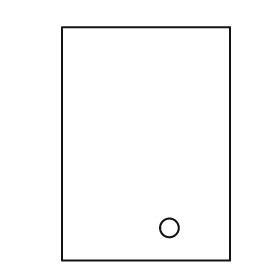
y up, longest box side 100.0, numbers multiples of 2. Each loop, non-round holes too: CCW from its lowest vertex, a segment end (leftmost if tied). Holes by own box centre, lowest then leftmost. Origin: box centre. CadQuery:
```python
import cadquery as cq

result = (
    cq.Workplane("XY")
    .moveTo(-36.0, -50.0)
    .lineTo(36.0, -50.0)
    .lineTo(36.0, 50.0)
    .lineTo(-36.0, 50.0)
    .close()
    .moveTo(10.0, -36.0)
    .circle(4.0)
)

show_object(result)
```